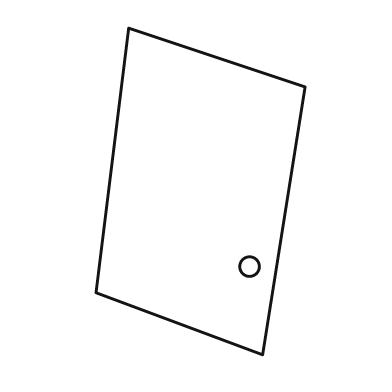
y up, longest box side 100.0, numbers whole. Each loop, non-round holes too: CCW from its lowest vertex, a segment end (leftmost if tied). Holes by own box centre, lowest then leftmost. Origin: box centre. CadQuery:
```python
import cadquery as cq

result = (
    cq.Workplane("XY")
    .moveTo(19.0, -50.0)
    .lineTo(32.0, 32.0)
    .lineTo(-22.0, 50.0)
    .lineTo(-32.0, -31.0)
    .close()
    .moveTo(15.0, -23.0)
    .circle(3.0)
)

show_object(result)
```